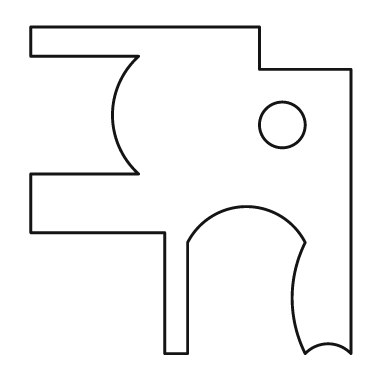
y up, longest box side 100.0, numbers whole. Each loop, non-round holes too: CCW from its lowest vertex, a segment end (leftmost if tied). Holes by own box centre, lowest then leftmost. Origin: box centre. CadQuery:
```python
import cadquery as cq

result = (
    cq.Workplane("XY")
    .moveTo(-8.0, -50.0)
    .lineTo(-1.0, -50.0)
    .lineTo(-1.0, -16.0)
    .threePointArc((17.0, -5.0), (35.0, -16.0))
    .threePointArc((31.0, -33.0), (35.0, -50.0))
    .threePointArc((42.0, -47.0), (49.0, -50.0))
    .lineTo(49.0, 37.0)
    .lineTo(21.0, 37.0)
    .lineTo(21.0, 50.0)
    .lineTo(-49.0, 50.0)
    .lineTo(-49.0, 41.0)
    .lineTo(-16.0, 41.0)
    .threePointArc((-24.0, 23.0), (-16.0, 5.0))
    .lineTo(-49.0, 5.0)
    .lineTo(-49.0, -13.0)
    .lineTo(-8.0, -13.0)
    .close()
    .moveTo(28.0, 20.0)
    .circle(7.0)
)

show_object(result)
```